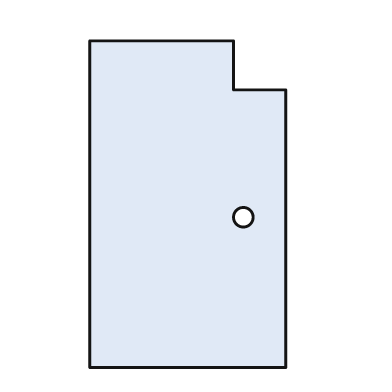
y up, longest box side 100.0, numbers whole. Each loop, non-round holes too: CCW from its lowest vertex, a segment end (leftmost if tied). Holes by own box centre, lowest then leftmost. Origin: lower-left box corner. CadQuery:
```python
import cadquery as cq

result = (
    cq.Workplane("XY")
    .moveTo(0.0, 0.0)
    .lineTo(60.0, 0.0)
    .lineTo(60.0, 85.0)
    .lineTo(44.0, 85.0)
    .lineTo(44.0, 100.0)
    .lineTo(0.0, 100.0)
    .close()
    .moveTo(47.0, 46.0)
    .circle(3.0)
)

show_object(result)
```